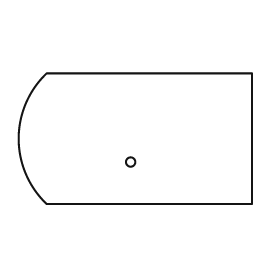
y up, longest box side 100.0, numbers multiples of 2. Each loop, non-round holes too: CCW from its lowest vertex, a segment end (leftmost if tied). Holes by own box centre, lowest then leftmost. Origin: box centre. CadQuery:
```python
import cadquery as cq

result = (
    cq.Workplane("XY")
    .moveTo(-38.0, -28.0)
    .lineTo(50.0, -28.0)
    .lineTo(50.0, 28.0)
    .lineTo(-38.0, 28.0)
    .threePointArc((-50.0, 0.0), (-38.0, -28.0))
    .close()
    .moveTo(-2.0, -10.0)
    .circle(2.0)
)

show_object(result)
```